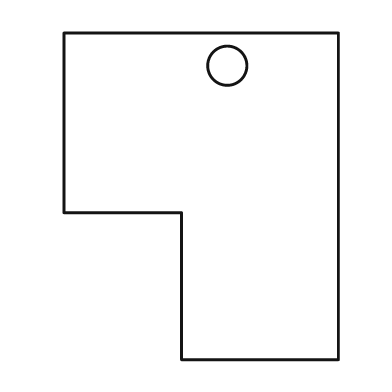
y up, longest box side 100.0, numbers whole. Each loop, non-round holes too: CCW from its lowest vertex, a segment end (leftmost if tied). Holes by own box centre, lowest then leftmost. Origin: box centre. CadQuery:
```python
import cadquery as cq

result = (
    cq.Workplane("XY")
    .moveTo(-6.0, -50.0)
    .lineTo(42.0, -50.0)
    .lineTo(42.0, 50.0)
    .lineTo(-42.0, 50.0)
    .lineTo(-42.0, -5.0)
    .lineTo(-6.0, -5.0)
    .close()
    .moveTo(8.0, 40.0)
    .circle(6.0)
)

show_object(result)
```